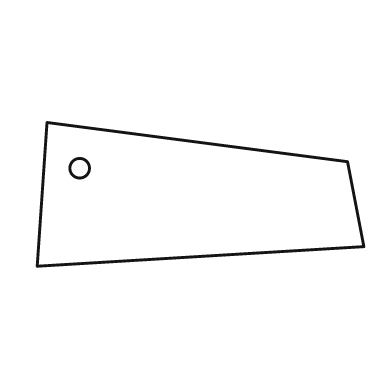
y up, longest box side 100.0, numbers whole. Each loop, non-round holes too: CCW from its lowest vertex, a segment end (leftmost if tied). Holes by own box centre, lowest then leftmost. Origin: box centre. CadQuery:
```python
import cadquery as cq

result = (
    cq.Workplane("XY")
    .moveTo(-50.0, -22.0)
    .lineTo(50.0, -16.0)
    .lineTo(45.0, 10.0)
    .lineTo(-47.0, 22.0)
    .close()
    .moveTo(-37.0, 8.0)
    .circle(3.0)
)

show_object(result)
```